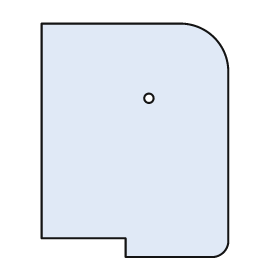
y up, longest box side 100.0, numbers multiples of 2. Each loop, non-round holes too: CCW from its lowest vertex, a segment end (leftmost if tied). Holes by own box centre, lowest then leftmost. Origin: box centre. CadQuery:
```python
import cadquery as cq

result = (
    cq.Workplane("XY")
    .moveTo(-4.0, -50.0)
    .lineTo(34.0, -50.0)
    .threePointArc((38.0, -48.0), (40.0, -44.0))
    .lineTo(40.0, 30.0)
    .threePointArc((34.0, 44.0), (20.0, 50.0))
    .lineTo(-40.0, 50.0)
    .lineTo(-40.0, -42.0)
    .lineTo(-4.0, -42.0)
    .close()
    .moveTo(6.0, 18.0)
    .circle(2.0)
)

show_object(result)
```